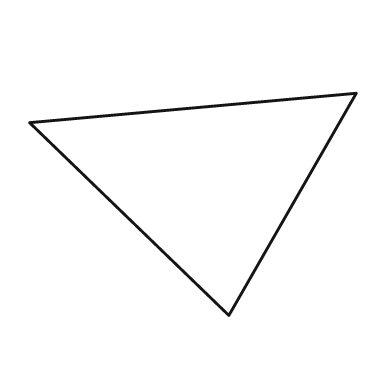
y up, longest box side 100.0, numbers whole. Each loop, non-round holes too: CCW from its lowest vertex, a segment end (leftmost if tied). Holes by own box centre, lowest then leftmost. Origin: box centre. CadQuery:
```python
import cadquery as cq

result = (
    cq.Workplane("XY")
    .moveTo(11.0, -34.0)
    .lineTo(50.0, 34.0)
    .lineTo(-50.0, 25.0)
    .close()
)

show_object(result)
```